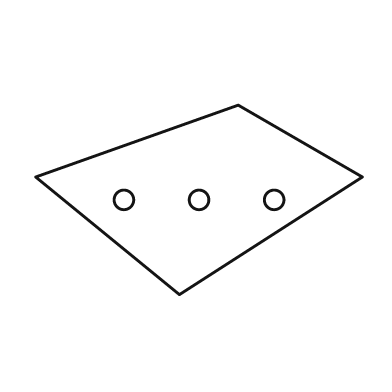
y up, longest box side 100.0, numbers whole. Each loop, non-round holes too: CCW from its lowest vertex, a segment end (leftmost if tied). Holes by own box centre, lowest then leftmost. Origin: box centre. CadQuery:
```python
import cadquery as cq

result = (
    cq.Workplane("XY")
    .moveTo(-6.0, -29.0)
    .lineTo(50.0, 7.0)
    .lineTo(12.0, 29.0)
    .lineTo(-50.0, 7.0)
    .close()
    .moveTo(-23.0, 0.0)
    .circle(3.0)
    .moveTo(0.0, 0.0)
    .circle(3.0)
    .moveTo(23.0, 0.0)
    .circle(3.0)
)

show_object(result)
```